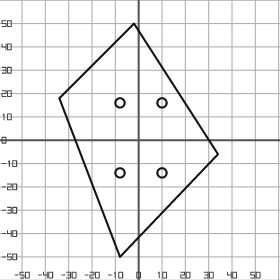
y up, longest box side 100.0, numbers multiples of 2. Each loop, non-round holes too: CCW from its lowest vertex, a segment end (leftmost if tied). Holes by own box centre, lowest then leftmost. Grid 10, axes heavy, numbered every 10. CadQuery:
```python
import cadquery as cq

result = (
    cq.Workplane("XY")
    .moveTo(-8.0, -50.0)
    .lineTo(34.0, -6.0)
    .lineTo(-2.0, 50.0)
    .lineTo(-34.0, 18.0)
    .close()
    .moveTo(-8.0, -14.0)
    .circle(2.0)
    .moveTo(10.0, -14.0)
    .circle(2.0)
    .moveTo(-8.0, 16.0)
    .circle(2.0)
    .moveTo(10.0, 16.0)
    .circle(2.0)
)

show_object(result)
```